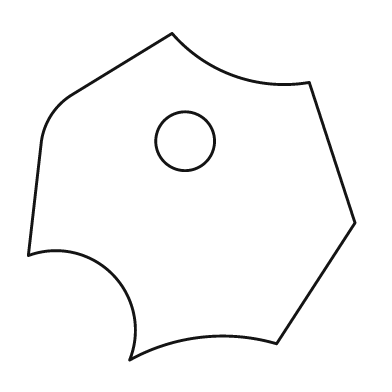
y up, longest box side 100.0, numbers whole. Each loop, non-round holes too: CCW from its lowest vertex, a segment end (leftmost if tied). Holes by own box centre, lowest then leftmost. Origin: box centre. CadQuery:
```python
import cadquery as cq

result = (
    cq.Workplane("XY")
    .moveTo(-19.0, -50.0)
    .threePointArc((3.0, -43.0), (26.0, -45.0))
    .lineTo(50.0, -8.0)
    .lineTo(36.0, 35.0)
    .threePointArc((13.0, 37.0), (-6.0, 50.0))
    .lineTo(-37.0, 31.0)
    .threePointArc((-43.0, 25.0), (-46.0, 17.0))
    .lineTo(-50.0, -18.0)
    .threePointArc((-24.0, -24.0), (-19.0, -50.0))
    .close()
    .moveTo(-2.0, 17.0)
    .circle(9.0)
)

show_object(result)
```